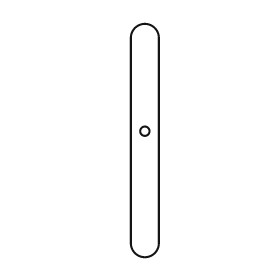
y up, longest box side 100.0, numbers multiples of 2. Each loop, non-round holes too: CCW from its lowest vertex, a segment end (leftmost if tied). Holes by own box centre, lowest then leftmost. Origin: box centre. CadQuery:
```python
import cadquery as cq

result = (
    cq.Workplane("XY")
    .moveTo(-6.0, -44.0)
    .threePointArc((0.0, -50.0), (6.0, -44.0))
    .lineTo(6.0, 44.0)
    .threePointArc((0.0, 50.0), (-6.0, 44.0))
    .close()
    .moveTo(0.0, 4.0)
    .circle(2.0)
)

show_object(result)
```